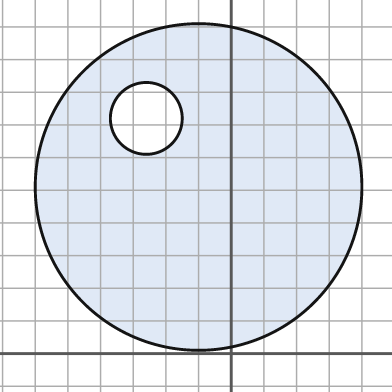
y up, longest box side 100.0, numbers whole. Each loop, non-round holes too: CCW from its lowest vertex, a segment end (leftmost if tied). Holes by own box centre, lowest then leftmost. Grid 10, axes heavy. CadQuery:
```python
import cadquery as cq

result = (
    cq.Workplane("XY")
    .moveTo(-10.0, 51.0)
    .circle(50.0)
    .moveTo(-26.0, 72.0)
    .circle(11.0)
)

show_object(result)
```